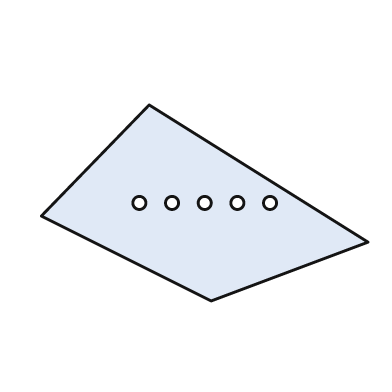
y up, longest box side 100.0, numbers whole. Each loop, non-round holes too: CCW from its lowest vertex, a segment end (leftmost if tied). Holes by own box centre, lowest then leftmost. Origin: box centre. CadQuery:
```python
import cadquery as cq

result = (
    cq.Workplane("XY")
    .moveTo(2.0, -30.0)
    .lineTo(50.0, -12.0)
    .lineTo(-17.0, 30.0)
    .lineTo(-50.0, -4.0)
    .close()
    .moveTo(-20.0, 0.0)
    .circle(2.0)
    .moveTo(-10.0, 0.0)
    .circle(2.0)
    .moveTo(0.0, 0.0)
    .circle(2.0)
    .moveTo(10.0, 0.0)
    .circle(2.0)
    .moveTo(20.0, 0.0)
    .circle(2.0)
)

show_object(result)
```